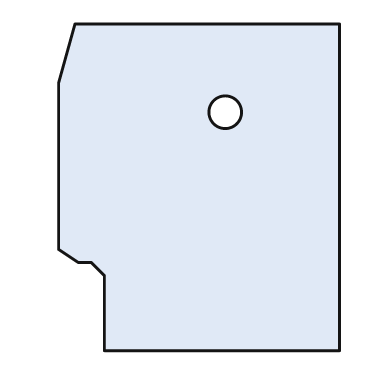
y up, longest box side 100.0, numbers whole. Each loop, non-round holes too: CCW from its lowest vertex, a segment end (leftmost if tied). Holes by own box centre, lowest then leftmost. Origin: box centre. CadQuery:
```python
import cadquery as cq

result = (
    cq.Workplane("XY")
    .moveTo(-29.0, -50.0)
    .lineTo(43.0, -50.0)
    .lineTo(43.0, 50.0)
    .lineTo(-38.0, 50.0)
    .lineTo(-43.0, 32.0)
    .lineTo(-43.0, -19.0)
    .lineTo(-37.0, -23.0)
    .lineTo(-33.0, -23.0)
    .lineTo(-29.0, -27.0)
    .close()
    .moveTo(8.0, 23.0)
    .circle(5.0)
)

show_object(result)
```